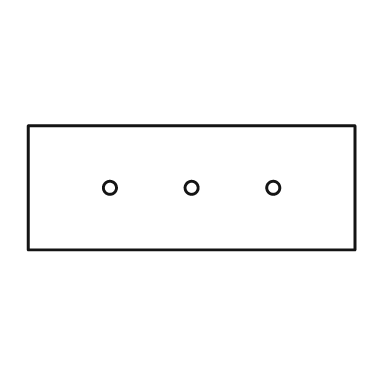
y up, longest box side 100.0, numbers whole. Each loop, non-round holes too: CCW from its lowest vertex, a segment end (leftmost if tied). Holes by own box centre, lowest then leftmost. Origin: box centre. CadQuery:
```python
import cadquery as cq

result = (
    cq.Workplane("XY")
    .moveTo(-50.0, -19.0)
    .lineTo(50.0, -19.0)
    .lineTo(50.0, 19.0)
    .lineTo(-50.0, 19.0)
    .close()
    .moveTo(-25.0, 0.0)
    .circle(2.0)
    .moveTo(0.0, 0.0)
    .circle(2.0)
    .moveTo(25.0, 0.0)
    .circle(2.0)
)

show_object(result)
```